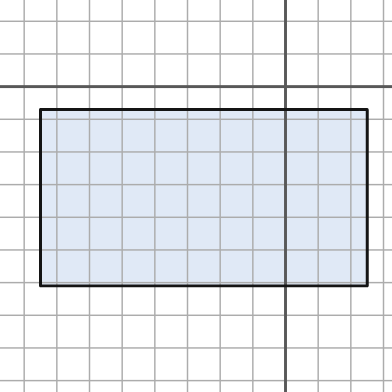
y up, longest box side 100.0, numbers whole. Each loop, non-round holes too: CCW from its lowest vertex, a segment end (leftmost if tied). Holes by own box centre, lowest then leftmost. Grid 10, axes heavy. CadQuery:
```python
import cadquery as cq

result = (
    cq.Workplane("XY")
    .moveTo(-75.0, -61.0)
    .lineTo(25.0, -61.0)
    .lineTo(25.0, -7.0)
    .lineTo(-75.0, -7.0)
    .close()
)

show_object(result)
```